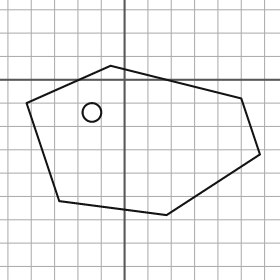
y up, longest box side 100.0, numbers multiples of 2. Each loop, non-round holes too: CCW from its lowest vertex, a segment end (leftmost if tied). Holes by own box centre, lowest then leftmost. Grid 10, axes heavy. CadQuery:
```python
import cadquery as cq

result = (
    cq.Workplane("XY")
    .moveTo(18.0, -58.0)
    .lineTo(58.0, -32.0)
    .lineTo(50.0, -8.0)
    .lineTo(-6.0, 6.0)
    .lineTo(-42.0, -10.0)
    .lineTo(-28.0, -52.0)
    .close()
    .moveTo(-14.0, -14.0)
    .circle(4.0)
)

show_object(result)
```